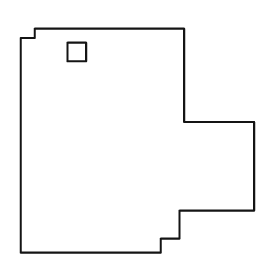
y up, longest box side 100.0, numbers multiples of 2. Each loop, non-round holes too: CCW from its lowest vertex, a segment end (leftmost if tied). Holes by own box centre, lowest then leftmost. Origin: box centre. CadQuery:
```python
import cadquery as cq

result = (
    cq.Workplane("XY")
    .moveTo(-50.0, -48.0)
    .lineTo(10.0, -48.0)
    .lineTo(10.0, -42.0)
    .lineTo(18.0, -42.0)
    .lineTo(18.0, -30.0)
    .lineTo(50.0, -30.0)
    .lineTo(50.0, 8.0)
    .lineTo(20.0, 8.0)
    .lineTo(20.0, 48.0)
    .lineTo(-44.0, 48.0)
    .lineTo(-44.0, 44.0)
    .lineTo(-50.0, 44.0)
    .close()
    .moveTo(-30.0, 34.0)
    .lineTo(-22.0, 34.0)
    .lineTo(-22.0, 42.0)
    .lineTo(-30.0, 42.0)
    .close()
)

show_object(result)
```